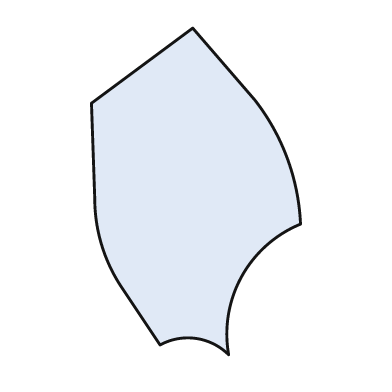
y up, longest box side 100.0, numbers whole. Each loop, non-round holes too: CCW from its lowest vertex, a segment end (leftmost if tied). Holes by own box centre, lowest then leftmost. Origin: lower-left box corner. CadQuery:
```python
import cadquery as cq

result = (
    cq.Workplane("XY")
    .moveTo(42.0, 0.0)
    .threePointArc((46.0, 24.0), (64.0, 40.0))
    .threePointArc((60.0, 60.0), (50.0, 78.0))
    .lineTo(31.0, 100.0)
    .lineTo(0.0, 77.0)
    .lineTo(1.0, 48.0)
    .threePointArc((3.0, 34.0), (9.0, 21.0))
    .lineTo(21.0, 3.0)
    .threePointArc((32.0, 5.0), (42.0, 0.0))
    .close()
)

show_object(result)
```